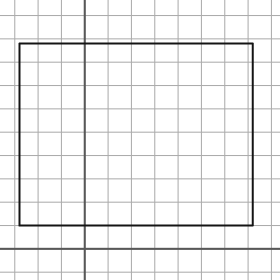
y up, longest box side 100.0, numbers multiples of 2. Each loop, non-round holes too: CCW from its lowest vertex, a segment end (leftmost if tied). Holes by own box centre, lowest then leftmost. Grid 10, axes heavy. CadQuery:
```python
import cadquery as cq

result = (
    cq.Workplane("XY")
    .moveTo(-28.0, 10.0)
    .lineTo(72.0, 10.0)
    .lineTo(72.0, 88.0)
    .lineTo(-28.0, 88.0)
    .close()
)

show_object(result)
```